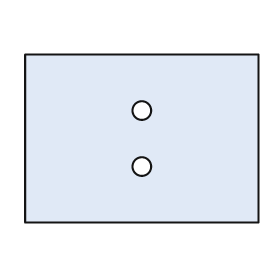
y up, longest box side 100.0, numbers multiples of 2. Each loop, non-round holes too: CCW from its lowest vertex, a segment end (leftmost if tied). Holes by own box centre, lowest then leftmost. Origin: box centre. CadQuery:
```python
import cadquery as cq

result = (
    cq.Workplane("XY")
    .moveTo(-50.0, -36.0)
    .lineTo(50.0, -36.0)
    .lineTo(50.0, 36.0)
    .lineTo(-50.0, 36.0)
    .close()
    .moveTo(0.0, -12.0)
    .circle(4.0)
    .moveTo(0.0, 12.0)
    .circle(4.0)
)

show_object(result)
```